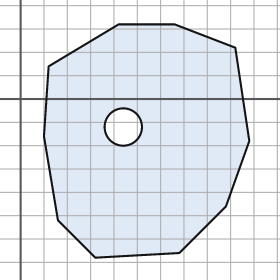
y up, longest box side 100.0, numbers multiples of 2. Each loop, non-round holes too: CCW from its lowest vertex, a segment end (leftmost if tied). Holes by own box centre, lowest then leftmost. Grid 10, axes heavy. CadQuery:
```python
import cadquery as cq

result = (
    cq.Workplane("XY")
    .moveTo(32.0, -68.0)
    .lineTo(68.0, -66.0)
    .lineTo(88.0, -46.0)
    .lineTo(98.0, -18.0)
    .lineTo(92.0, 22.0)
    .lineTo(66.0, 32.0)
    .lineTo(42.0, 32.0)
    .lineTo(12.0, 14.0)
    .lineTo(10.0, -16.0)
    .lineTo(16.0, -52.0)
    .close()
    .moveTo(44.0, -12.0)
    .circle(8.0)
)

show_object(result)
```